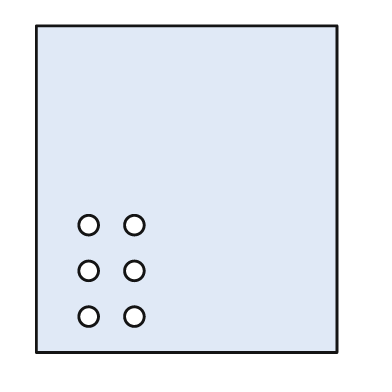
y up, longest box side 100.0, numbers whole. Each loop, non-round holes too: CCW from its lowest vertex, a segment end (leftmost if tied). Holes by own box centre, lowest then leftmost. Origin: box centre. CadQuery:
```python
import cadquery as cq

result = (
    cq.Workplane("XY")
    .moveTo(-46.0, -50.0)
    .lineTo(46.0, -50.0)
    .lineTo(46.0, 50.0)
    .lineTo(-46.0, 50.0)
    .close()
    .moveTo(-30.0, -39.0)
    .circle(3.0)
    .moveTo(-16.0, -39.0)
    .circle(3.0)
    .moveTo(-30.0, -25.0)
    .circle(3.0)
    .moveTo(-16.0, -25.0)
    .circle(3.0)
    .moveTo(-30.0, -11.0)
    .circle(3.0)
    .moveTo(-16.0, -11.0)
    .circle(3.0)
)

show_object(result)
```